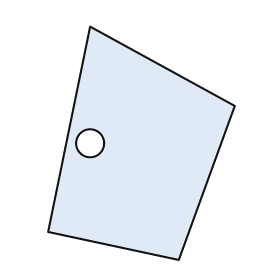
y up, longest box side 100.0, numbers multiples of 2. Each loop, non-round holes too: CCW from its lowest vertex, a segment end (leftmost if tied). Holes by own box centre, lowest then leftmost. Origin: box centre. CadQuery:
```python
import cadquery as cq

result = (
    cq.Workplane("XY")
    .moveTo(16.0, -50.0)
    .lineTo(40.0, 16.0)
    .lineTo(-22.0, 50.0)
    .lineTo(-40.0, -38.0)
    .close()
    .moveTo(-22.0, 0.0)
    .circle(6.0)
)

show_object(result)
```